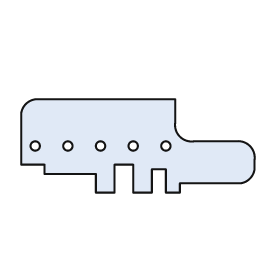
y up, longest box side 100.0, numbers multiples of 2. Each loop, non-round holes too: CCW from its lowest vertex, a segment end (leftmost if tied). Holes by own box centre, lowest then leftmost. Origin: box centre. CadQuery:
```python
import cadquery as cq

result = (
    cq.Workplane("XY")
    .moveTo(-18.0, -20.0)
    .lineTo(-10.0, -20.0)
    .lineTo(-10.0, -8.0)
    .lineTo(-2.0, -8.0)
    .lineTo(-2.0, -20.0)
    .lineTo(6.0, -20.0)
    .lineTo(6.0, -10.0)
    .lineTo(12.0, -10.0)
    .lineTo(12.0, -20.0)
    .lineTo(18.0, -20.0)
    .lineTo(18.0, -16.0)
    .lineTo(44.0, -16.0)
    .threePointArc((48.0, -14.0), (50.0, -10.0))
    .lineTo(50.0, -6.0)
    .threePointArc((48.0, 0.0), (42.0, 2.0))
    .lineTo(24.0, 2.0)
    .threePointArc((18.0, 4.0), (16.0, 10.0))
    .lineTo(16.0, 20.0)
    .lineTo(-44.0, 20.0)
    .threePointArc((-48.0, 18.0), (-50.0, 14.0))
    .lineTo(-50.0, -8.0)
    .lineTo(-40.0, -8.0)
    .lineTo(-40.0, -12.0)
    .lineTo(-18.0, -12.0)
    .close()
    .moveTo(-44.0, 0.0)
    .circle(2.0)
    .moveTo(-30.0, 0.0)
    .circle(2.0)
    .moveTo(-16.0, 0.0)
    .circle(2.0)
    .moveTo(-2.0, 0.0)
    .circle(2.0)
    .moveTo(12.0, 0.0)
    .circle(2.0)
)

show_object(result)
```